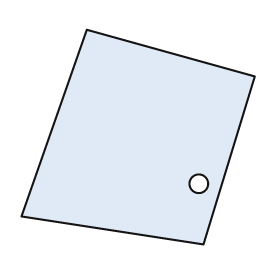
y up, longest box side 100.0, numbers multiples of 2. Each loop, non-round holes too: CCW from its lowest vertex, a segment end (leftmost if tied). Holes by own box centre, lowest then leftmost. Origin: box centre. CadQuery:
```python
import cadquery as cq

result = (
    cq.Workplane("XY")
    .moveTo(28.0, -46.0)
    .lineTo(50.0, 26.0)
    .lineTo(-22.0, 46.0)
    .lineTo(-50.0, -34.0)
    .close()
    .moveTo(26.0, -20.0)
    .circle(4.0)
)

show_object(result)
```